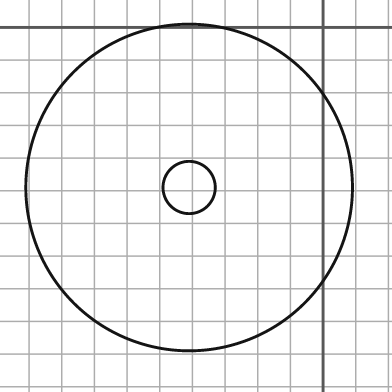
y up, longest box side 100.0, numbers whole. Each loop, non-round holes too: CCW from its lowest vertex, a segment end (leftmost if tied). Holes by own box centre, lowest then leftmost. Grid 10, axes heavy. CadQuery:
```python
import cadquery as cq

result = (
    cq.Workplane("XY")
    .moveTo(-41.0, -49.0)
    .circle(50.0)
    .moveTo(-41.0, -49.0)
    .circle(8.0)
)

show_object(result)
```